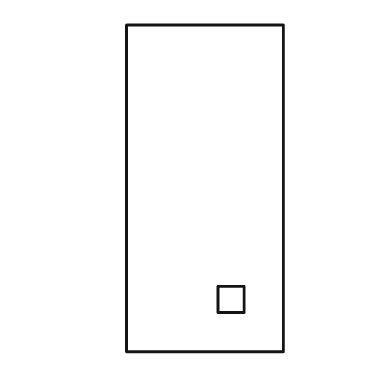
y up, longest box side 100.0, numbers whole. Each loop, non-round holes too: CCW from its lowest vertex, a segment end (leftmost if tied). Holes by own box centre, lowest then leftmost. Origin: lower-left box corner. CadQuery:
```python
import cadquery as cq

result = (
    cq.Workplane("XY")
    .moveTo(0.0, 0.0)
    .lineTo(48.0, 0.0)
    .lineTo(48.0, 100.0)
    .lineTo(0.0, 100.0)
    .close()
    .moveTo(28.0, 12.0)
    .lineTo(36.0, 12.0)
    .lineTo(36.0, 20.0)
    .lineTo(28.0, 20.0)
    .close()
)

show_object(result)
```